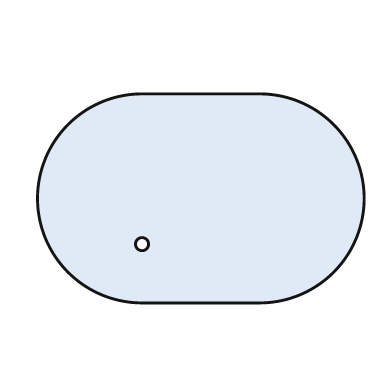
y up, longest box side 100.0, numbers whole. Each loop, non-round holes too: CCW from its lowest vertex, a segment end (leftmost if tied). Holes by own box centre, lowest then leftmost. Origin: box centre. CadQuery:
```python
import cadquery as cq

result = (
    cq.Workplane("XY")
    .moveTo(-18.0, -32.0)
    .lineTo(18.0, -32.0)
    .threePointArc((50.0, 0.0), (18.0, 32.0))
    .lineTo(-18.0, 32.0)
    .threePointArc((-50.0, 0.0), (-18.0, -32.0))
    .close()
    .moveTo(-18.0, -14.0)
    .circle(2.0)
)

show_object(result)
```